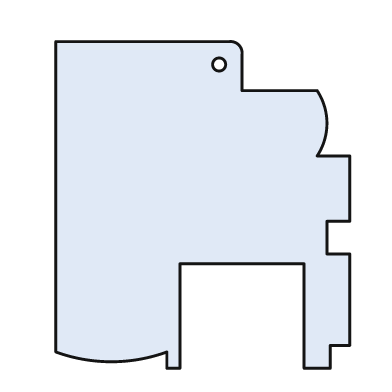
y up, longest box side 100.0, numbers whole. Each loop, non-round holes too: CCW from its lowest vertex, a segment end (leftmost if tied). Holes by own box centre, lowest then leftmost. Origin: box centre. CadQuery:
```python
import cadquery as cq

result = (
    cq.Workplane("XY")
    .moveTo(-11.0, -50.0)
    .lineTo(-7.0, -50.0)
    .lineTo(-7.0, -18.0)
    .lineTo(31.0, -18.0)
    .lineTo(31.0, -50.0)
    .lineTo(39.0, -50.0)
    .lineTo(39.0, -43.0)
    .lineTo(45.0, -43.0)
    .lineTo(45.0, -15.0)
    .lineTo(38.0, -15.0)
    .lineTo(38.0, -5.0)
    .lineTo(45.0, -5.0)
    .lineTo(45.0, 15.0)
    .lineTo(35.0, 15.0)
    .threePointArc((38.0, 25.0), (35.0, 35.0))
    .lineTo(12.0, 35.0)
    .lineTo(12.0, 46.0)
    .threePointArc((11.0, 49.0), (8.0, 50.0))
    .lineTo(-45.0, 50.0)
    .lineTo(-45.0, -45.0)
    .threePointArc((-28.0, -48.0), (-11.0, -45.0))
    .close()
    .moveTo(5.0, 43.0)
    .circle(2.0)
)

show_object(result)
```